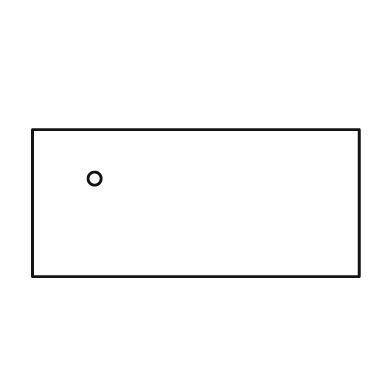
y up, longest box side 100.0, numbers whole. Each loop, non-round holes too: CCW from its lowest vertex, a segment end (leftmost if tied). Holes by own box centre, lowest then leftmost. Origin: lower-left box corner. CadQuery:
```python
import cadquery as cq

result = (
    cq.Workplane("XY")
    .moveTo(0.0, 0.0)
    .lineTo(100.0, 0.0)
    .lineTo(100.0, 45.0)
    .lineTo(0.0, 45.0)
    .close()
    .moveTo(19.0, 30.0)
    .circle(2.0)
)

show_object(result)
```